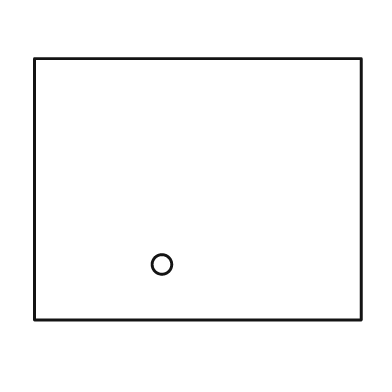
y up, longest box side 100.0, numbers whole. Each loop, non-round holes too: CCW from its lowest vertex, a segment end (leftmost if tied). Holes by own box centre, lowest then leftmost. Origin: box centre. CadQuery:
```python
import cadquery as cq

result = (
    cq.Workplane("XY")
    .moveTo(-50.0, -40.0)
    .lineTo(50.0, -40.0)
    .lineTo(50.0, 40.0)
    .lineTo(-50.0, 40.0)
    .close()
    .moveTo(-11.0, -23.0)
    .circle(3.0)
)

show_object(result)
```